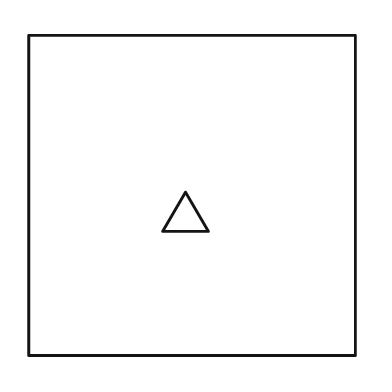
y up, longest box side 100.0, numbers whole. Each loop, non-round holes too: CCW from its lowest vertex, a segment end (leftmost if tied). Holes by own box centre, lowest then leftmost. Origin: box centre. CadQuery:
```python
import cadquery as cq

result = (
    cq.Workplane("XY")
    .moveTo(-50.0, -49.0)
    .lineTo(50.0, -49.0)
    .lineTo(50.0, 49.0)
    .lineTo(-50.0, 49.0)
    .close()
    .moveTo(-9.0, -11.0)
    .lineTo(5.0, -11.0)
    .lineTo(-2.0, 1.0)
    .close()
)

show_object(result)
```